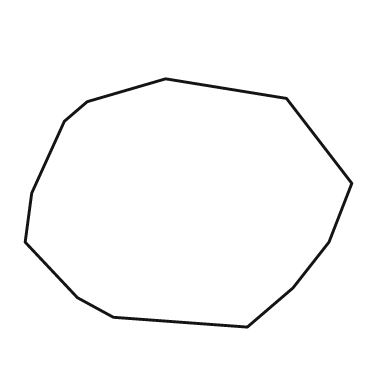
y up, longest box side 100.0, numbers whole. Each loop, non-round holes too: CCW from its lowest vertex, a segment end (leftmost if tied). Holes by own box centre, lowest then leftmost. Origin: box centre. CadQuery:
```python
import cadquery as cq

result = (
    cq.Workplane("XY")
    .moveTo(18.0, -38.0)
    .lineTo(32.0, -26.0)
    .lineTo(43.0, -12.0)
    .lineTo(50.0, 6.0)
    .lineTo(30.0, 32.0)
    .lineTo(-7.0, 38.0)
    .lineTo(-31.0, 31.0)
    .lineTo(-38.0, 25.0)
    .lineTo(-48.0, 3.0)
    .lineTo(-50.0, -12.0)
    .lineTo(-34.0, -29.0)
    .lineTo(-23.0, -35.0)
    .close()
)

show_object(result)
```